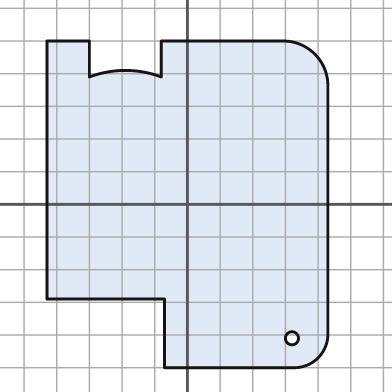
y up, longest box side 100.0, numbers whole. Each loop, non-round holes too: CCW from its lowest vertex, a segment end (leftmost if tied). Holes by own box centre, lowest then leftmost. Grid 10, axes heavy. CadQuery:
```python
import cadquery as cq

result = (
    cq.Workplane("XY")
    .moveTo(-7.0, -50.0)
    .lineTo(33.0, -50.0)
    .threePointArc((40.0, -47.0), (43.0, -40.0))
    .lineTo(43.0, 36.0)
    .threePointArc((39.0, 46.0), (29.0, 50.0))
    .lineTo(-8.0, 50.0)
    .lineTo(-8.0, 39.0)
    .threePointArc((-19.0, 41.0), (-30.0, 39.0))
    .lineTo(-30.0, 50.0)
    .lineTo(-43.0, 50.0)
    .lineTo(-43.0, -29.0)
    .lineTo(-7.0, -29.0)
    .close()
    .moveTo(32.0, -41.0)
    .circle(2.0)
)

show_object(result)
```